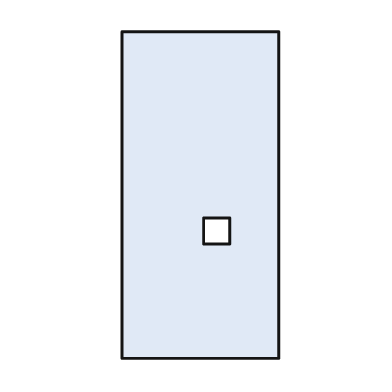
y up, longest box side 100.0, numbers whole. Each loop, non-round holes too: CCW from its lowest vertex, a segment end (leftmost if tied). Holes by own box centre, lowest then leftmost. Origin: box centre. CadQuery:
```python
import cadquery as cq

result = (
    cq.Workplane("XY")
    .moveTo(-24.0, -50.0)
    .lineTo(24.0, -50.0)
    .lineTo(24.0, 50.0)
    .lineTo(-24.0, 50.0)
    .close()
    .moveTo(1.0, -15.0)
    .lineTo(9.0, -15.0)
    .lineTo(9.0, -7.0)
    .lineTo(1.0, -7.0)
    .close()
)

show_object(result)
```